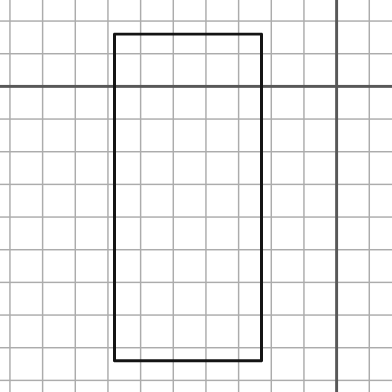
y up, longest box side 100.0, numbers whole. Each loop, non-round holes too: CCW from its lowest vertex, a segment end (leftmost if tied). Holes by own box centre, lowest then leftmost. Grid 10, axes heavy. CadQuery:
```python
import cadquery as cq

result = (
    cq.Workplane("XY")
    .moveTo(-68.0, -84.0)
    .lineTo(-23.0, -84.0)
    .lineTo(-23.0, 16.0)
    .lineTo(-68.0, 16.0)
    .close()
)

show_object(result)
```